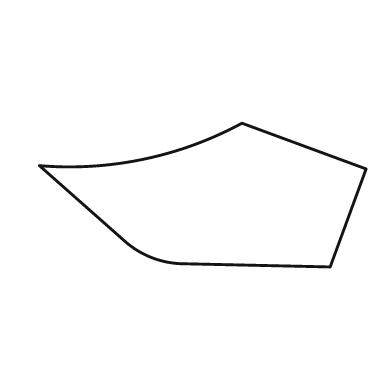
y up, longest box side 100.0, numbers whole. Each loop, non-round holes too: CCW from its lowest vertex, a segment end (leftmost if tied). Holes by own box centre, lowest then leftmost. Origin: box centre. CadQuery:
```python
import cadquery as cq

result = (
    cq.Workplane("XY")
    .moveTo(39.0, -22.0)
    .lineTo(50.0, 8.0)
    .lineTo(12.0, 22.0)
    .threePointArc((-18.0, 11.0), (-50.0, 9.0))
    .lineTo(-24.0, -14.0)
    .threePointArc((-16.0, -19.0), (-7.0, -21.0))
    .close()
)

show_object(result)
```